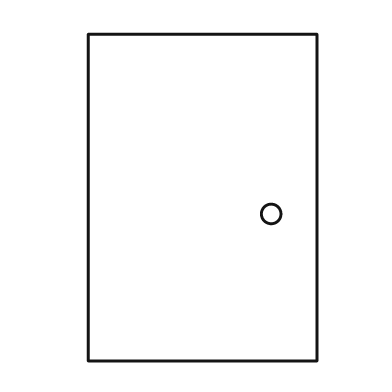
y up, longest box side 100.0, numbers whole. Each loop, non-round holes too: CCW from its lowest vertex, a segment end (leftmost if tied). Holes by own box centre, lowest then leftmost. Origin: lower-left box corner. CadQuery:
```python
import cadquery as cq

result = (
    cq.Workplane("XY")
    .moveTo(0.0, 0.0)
    .lineTo(70.0, 0.0)
    .lineTo(70.0, 100.0)
    .lineTo(0.0, 100.0)
    .close()
    .moveTo(56.0, 45.0)
    .circle(3.0)
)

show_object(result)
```